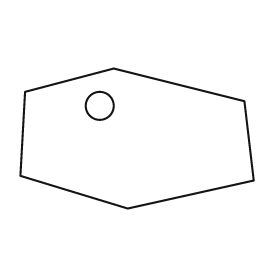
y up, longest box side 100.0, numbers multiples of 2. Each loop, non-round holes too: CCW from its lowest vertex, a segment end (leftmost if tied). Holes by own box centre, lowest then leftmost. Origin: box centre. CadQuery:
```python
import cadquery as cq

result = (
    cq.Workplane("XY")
    .moveTo(-4.0, -30.0)
    .lineTo(50.0, -18.0)
    .lineTo(46.0, 16.0)
    .lineTo(-10.0, 30.0)
    .lineTo(-48.0, 20.0)
    .lineTo(-50.0, -16.0)
    .close()
    .moveTo(-16.0, 14.0)
    .circle(6.0)
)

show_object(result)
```